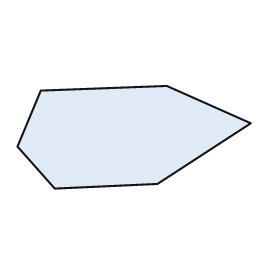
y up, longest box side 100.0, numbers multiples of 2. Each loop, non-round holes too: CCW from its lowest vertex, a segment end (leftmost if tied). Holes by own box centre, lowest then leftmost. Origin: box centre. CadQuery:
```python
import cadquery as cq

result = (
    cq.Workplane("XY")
    .moveTo(-34.0, -22.0)
    .lineTo(10.0, -20.0)
    .lineTo(50.0, 6.0)
    .lineTo(14.0, 22.0)
    .lineTo(-40.0, 20.0)
    .lineTo(-50.0, -4.0)
    .close()
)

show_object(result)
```